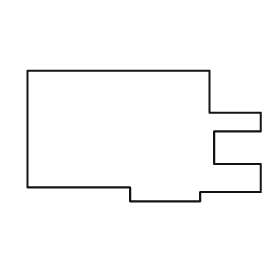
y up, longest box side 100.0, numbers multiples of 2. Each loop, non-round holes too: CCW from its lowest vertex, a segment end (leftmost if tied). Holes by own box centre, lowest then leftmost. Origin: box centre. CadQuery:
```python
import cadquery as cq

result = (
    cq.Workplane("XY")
    .moveTo(-6.0, -28.0)
    .lineTo(24.0, -28.0)
    .lineTo(24.0, -24.0)
    .lineTo(50.0, -24.0)
    .lineTo(50.0, -12.0)
    .lineTo(30.0, -12.0)
    .lineTo(30.0, 2.0)
    .lineTo(50.0, 2.0)
    .lineTo(50.0, 10.0)
    .lineTo(28.0, 10.0)
    .lineTo(28.0, 28.0)
    .lineTo(-50.0, 28.0)
    .lineTo(-50.0, -22.0)
    .lineTo(-6.0, -22.0)
    .close()
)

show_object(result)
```